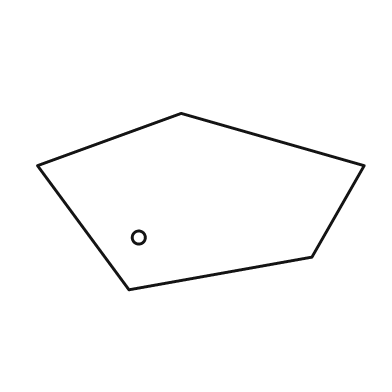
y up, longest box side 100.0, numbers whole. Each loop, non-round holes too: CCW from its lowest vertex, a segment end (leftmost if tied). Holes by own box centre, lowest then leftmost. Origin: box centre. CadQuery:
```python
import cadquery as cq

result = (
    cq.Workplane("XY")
    .moveTo(-22.0, -27.0)
    .lineTo(34.0, -17.0)
    .lineTo(50.0, 11.0)
    .lineTo(-6.0, 27.0)
    .lineTo(-50.0, 11.0)
    .close()
    .moveTo(-19.0, -11.0)
    .circle(2.0)
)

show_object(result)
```